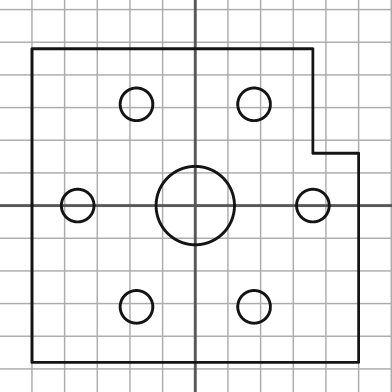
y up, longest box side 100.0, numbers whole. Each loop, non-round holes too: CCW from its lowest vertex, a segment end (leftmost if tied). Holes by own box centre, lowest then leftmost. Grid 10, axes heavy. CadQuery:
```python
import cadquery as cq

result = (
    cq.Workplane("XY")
    .moveTo(-50.0, -48.0)
    .lineTo(50.0, -48.0)
    .lineTo(50.0, 16.0)
    .lineTo(36.0, 16.0)
    .lineTo(36.0, 48.0)
    .lineTo(-50.0, 48.0)
    .close()
    .moveTo(-18.0, -31.0)
    .circle(5.0)
    .moveTo(18.0, -31.0)
    .circle(5.0)
    .moveTo(-36.0, 0.0)
    .circle(5.0)
    .moveTo(0.0, 0.0)
    .circle(12.0)
    .moveTo(36.0, 0.0)
    .circle(5.0)
    .moveTo(-18.0, 31.0)
    .circle(5.0)
    .moveTo(18.0, 31.0)
    .circle(5.0)
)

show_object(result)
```